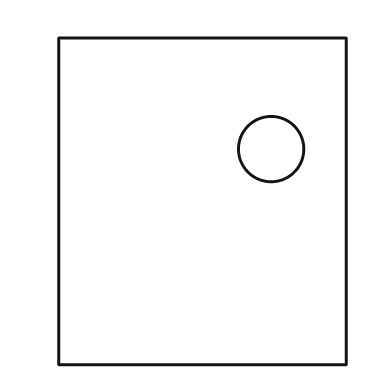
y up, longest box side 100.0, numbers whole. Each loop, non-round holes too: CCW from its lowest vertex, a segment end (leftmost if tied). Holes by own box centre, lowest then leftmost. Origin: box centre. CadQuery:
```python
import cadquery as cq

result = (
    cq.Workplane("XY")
    .moveTo(-44.0, -50.0)
    .lineTo(44.0, -50.0)
    .lineTo(44.0, 50.0)
    .lineTo(-44.0, 50.0)
    .close()
    .moveTo(21.0, 16.0)
    .circle(10.0)
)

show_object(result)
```